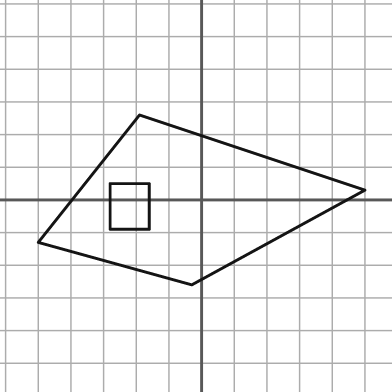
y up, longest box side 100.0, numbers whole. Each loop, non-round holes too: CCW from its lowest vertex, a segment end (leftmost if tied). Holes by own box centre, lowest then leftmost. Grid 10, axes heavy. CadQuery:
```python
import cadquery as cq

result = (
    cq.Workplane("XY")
    .moveTo(-3.0, -26.0)
    .lineTo(50.0, 3.0)
    .lineTo(-19.0, 26.0)
    .lineTo(-50.0, -13.0)
    .close()
    .moveTo(-28.0, -9.0)
    .lineTo(-16.0, -9.0)
    .lineTo(-16.0, 5.0)
    .lineTo(-28.0, 5.0)
    .close()
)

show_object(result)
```